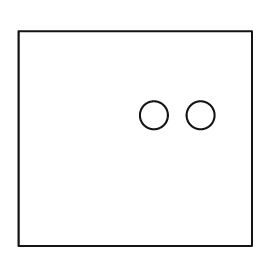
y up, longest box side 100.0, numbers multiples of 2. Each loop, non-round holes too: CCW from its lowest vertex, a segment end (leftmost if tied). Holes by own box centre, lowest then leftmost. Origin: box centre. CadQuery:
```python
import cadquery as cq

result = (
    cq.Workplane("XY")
    .moveTo(-50.0, -46.0)
    .lineTo(50.0, -46.0)
    .lineTo(50.0, 46.0)
    .lineTo(-50.0, 46.0)
    .close()
    .moveTo(8.0, 10.0)
    .circle(6.0)
    .moveTo(28.0, 10.0)
    .circle(6.0)
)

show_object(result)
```